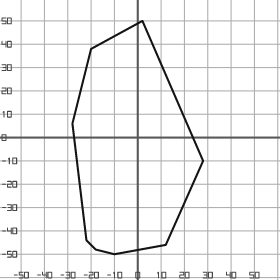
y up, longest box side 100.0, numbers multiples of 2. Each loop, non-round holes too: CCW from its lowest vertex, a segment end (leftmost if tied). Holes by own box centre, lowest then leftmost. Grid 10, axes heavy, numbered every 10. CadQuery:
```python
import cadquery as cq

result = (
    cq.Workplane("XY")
    .moveTo(-10.0, -50.0)
    .lineTo(12.0, -46.0)
    .lineTo(28.0, -10.0)
    .lineTo(2.0, 50.0)
    .lineTo(-20.0, 38.0)
    .lineTo(-28.0, 6.0)
    .lineTo(-22.0, -44.0)
    .lineTo(-18.0, -48.0)
    .close()
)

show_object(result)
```